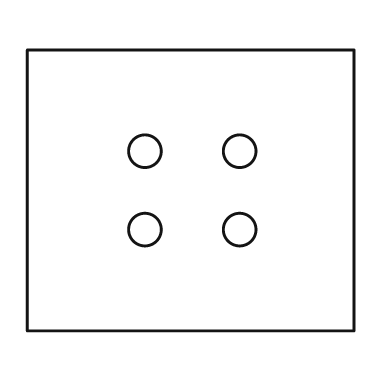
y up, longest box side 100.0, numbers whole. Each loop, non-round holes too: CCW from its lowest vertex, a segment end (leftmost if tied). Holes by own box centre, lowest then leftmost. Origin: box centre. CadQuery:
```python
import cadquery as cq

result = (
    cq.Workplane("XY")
    .moveTo(-50.0, -43.0)
    .lineTo(50.0, -43.0)
    .lineTo(50.0, 43.0)
    .lineTo(-50.0, 43.0)
    .close()
    .moveTo(-14.0, -12.0)
    .circle(5.0)
    .moveTo(15.0, -12.0)
    .circle(5.0)
    .moveTo(-14.0, 12.0)
    .circle(5.0)
    .moveTo(15.0, 12.0)
    .circle(5.0)
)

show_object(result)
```